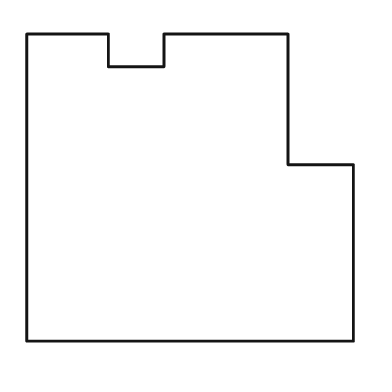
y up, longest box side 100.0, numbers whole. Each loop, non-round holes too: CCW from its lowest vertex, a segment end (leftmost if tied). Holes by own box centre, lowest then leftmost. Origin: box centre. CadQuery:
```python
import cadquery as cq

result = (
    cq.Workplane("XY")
    .moveTo(-50.0, -47.0)
    .lineTo(50.0, -47.0)
    .lineTo(50.0, 7.0)
    .lineTo(30.0, 7.0)
    .lineTo(30.0, 47.0)
    .lineTo(-8.0, 47.0)
    .lineTo(-8.0, 37.0)
    .lineTo(-25.0, 37.0)
    .lineTo(-25.0, 47.0)
    .lineTo(-50.0, 47.0)
    .close()
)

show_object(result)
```